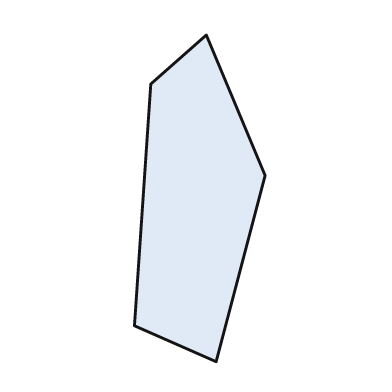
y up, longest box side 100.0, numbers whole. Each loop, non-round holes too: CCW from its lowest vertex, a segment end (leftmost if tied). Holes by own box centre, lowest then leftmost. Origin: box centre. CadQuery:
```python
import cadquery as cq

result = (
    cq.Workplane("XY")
    .moveTo(5.0, -50.0)
    .lineTo(20.0, 7.0)
    .lineTo(2.0, 50.0)
    .lineTo(-15.0, 35.0)
    .lineTo(-20.0, -39.0)
    .close()
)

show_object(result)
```